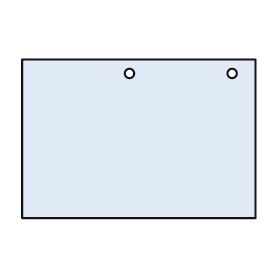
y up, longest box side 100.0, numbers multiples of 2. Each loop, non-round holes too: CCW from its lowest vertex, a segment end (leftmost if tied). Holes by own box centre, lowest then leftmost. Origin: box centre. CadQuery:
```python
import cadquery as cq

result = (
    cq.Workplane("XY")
    .moveTo(-50.0, -34.0)
    .lineTo(50.0, -34.0)
    .lineTo(50.0, 34.0)
    .lineTo(-50.0, 34.0)
    .close()
    .moveTo(-4.0, 28.0)
    .circle(2.0)
    .moveTo(40.0, 28.0)
    .circle(2.0)
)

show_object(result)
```